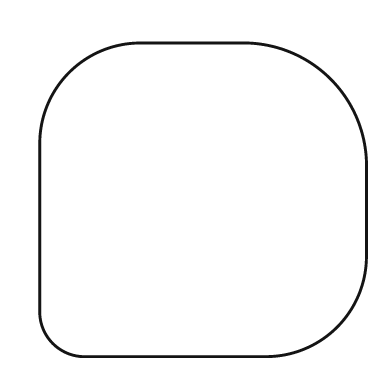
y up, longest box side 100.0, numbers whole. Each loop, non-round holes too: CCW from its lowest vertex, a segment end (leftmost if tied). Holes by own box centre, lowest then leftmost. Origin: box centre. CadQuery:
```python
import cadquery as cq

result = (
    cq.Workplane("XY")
    .moveTo(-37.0, -48.0)
    .lineTo(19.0, -48.0)
    .threePointArc((41.0, -39.0), (50.0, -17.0))
    .lineTo(50.0, 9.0)
    .threePointArc((39.0, 37.0), (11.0, 48.0))
    .lineTo(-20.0, 48.0)
    .threePointArc((-41.0, 39.0), (-50.0, 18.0))
    .lineTo(-50.0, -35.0)
    .threePointArc((-46.0, -44.0), (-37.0, -48.0))
    .close()
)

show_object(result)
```